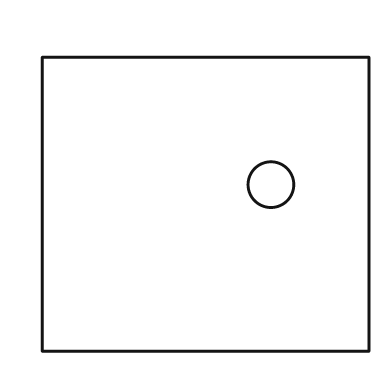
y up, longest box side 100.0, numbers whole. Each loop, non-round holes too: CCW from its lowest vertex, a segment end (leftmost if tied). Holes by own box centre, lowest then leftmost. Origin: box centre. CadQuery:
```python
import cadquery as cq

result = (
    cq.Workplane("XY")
    .moveTo(-50.0, -45.0)
    .lineTo(50.0, -45.0)
    .lineTo(50.0, 45.0)
    .lineTo(-50.0, 45.0)
    .close()
    .moveTo(20.0, 6.0)
    .circle(7.0)
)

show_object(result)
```